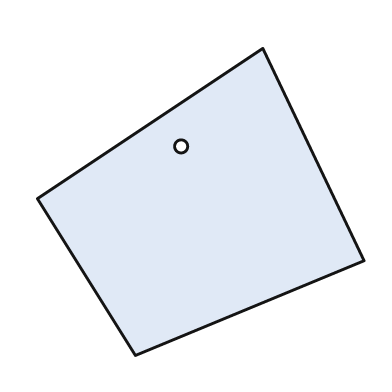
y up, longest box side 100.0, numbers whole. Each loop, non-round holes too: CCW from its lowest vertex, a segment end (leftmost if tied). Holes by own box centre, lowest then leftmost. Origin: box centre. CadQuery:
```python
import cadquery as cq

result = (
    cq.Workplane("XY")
    .moveTo(-20.0, -47.0)
    .lineTo(50.0, -18.0)
    .lineTo(19.0, 47.0)
    .lineTo(-50.0, 1.0)
    .close()
    .moveTo(-6.0, 17.0)
    .circle(2.0)
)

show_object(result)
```